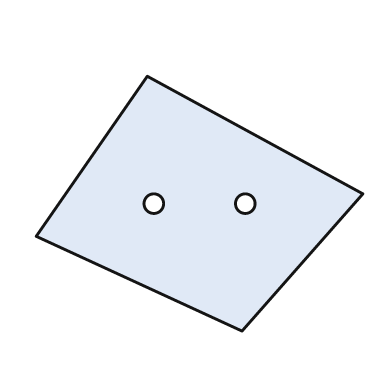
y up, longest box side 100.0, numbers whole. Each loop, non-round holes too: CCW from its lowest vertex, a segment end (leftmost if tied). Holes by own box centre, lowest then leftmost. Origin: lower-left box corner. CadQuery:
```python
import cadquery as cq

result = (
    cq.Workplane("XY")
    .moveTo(63.0, 0.0)
    .lineTo(100.0, 42.0)
    .lineTo(34.0, 78.0)
    .lineTo(0.0, 29.0)
    .close()
    .moveTo(36.0, 39.0)
    .circle(3.0)
    .moveTo(64.0, 39.0)
    .circle(3.0)
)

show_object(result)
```